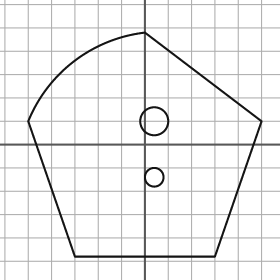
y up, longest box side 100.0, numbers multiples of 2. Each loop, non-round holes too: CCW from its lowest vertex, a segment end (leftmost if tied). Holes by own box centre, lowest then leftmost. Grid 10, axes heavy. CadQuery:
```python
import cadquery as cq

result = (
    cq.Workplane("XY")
    .moveTo(-30.0, -48.0)
    .lineTo(30.0, -48.0)
    .lineTo(50.0, 10.0)
    .lineTo(0.0, 48.0)
    .threePointArc((-30.0, 36.0), (-50.0, 10.0))
    .close()
    .moveTo(4.0, -14.0)
    .circle(4.0)
    .moveTo(4.0, 10.0)
    .circle(6.0)
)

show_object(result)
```